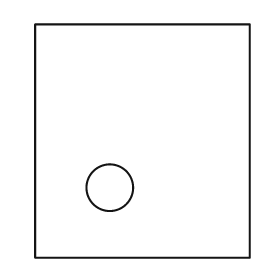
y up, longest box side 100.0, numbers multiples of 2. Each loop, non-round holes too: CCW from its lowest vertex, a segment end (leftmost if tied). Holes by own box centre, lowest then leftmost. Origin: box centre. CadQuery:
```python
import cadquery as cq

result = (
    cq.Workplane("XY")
    .moveTo(-46.0, -50.0)
    .lineTo(46.0, -50.0)
    .lineTo(46.0, 50.0)
    .lineTo(-46.0, 50.0)
    .close()
    .moveTo(-14.0, -20.0)
    .circle(10.0)
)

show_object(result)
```